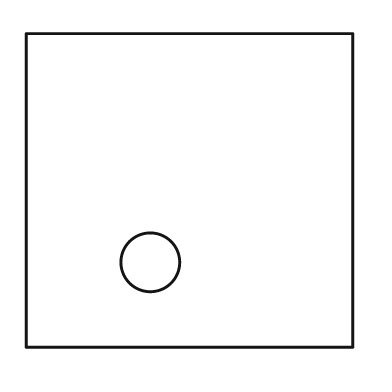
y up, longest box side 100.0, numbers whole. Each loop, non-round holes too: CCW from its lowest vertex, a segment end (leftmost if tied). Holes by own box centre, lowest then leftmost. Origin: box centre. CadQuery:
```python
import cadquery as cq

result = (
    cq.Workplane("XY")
    .moveTo(-50.0, -48.0)
    .lineTo(50.0, -48.0)
    .lineTo(50.0, 48.0)
    .lineTo(-50.0, 48.0)
    .close()
    .moveTo(-12.0, -22.0)
    .circle(9.0)
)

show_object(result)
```